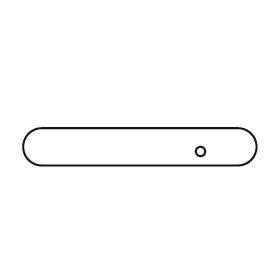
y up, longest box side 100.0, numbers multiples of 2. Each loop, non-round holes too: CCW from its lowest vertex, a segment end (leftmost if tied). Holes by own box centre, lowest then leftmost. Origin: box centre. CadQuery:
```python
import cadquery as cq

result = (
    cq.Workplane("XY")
    .moveTo(-42.0, -8.0)
    .lineTo(42.0, -8.0)
    .threePointArc((50.0, 0.0), (42.0, 8.0))
    .lineTo(-42.0, 8.0)
    .threePointArc((-50.0, 0.0), (-42.0, -8.0))
    .close()
    .moveTo(26.0, -2.0)
    .circle(2.0)
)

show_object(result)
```